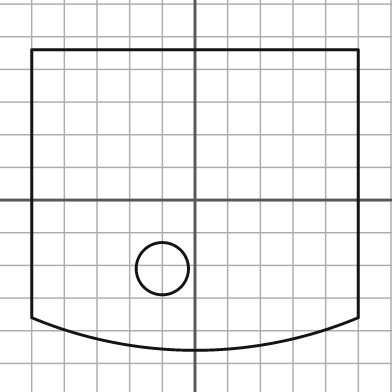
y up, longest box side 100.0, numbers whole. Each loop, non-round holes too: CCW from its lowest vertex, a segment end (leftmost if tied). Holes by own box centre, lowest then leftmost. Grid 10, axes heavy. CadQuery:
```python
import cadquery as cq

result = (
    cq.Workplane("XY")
    .moveTo(-50.0, -36.0)
    .threePointArc((0.0, -46.0), (50.0, -36.0))
    .lineTo(50.0, 46.0)
    .lineTo(-50.0, 46.0)
    .close()
    .moveTo(-10.0, -21.0)
    .circle(8.0)
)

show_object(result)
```